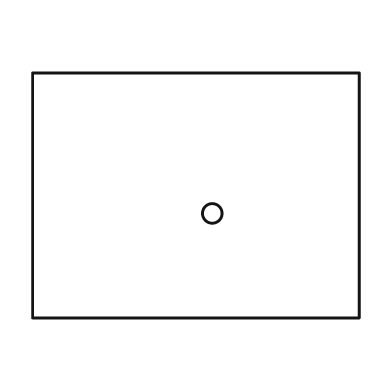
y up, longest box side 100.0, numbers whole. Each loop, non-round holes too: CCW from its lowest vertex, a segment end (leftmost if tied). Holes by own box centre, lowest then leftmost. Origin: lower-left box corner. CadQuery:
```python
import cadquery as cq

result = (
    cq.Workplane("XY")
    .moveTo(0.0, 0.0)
    .lineTo(100.0, 0.0)
    .lineTo(100.0, 75.0)
    .lineTo(0.0, 75.0)
    .close()
    .moveTo(55.0, 32.0)
    .circle(3.0)
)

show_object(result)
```